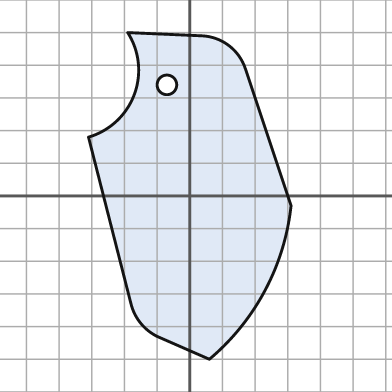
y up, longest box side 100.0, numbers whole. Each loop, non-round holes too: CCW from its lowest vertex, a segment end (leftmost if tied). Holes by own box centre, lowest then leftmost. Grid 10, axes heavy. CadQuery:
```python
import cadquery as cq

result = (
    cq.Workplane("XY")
    .moveTo(6.0, -50.0)
    .threePointArc((23.0, -29.0), (31.0, -3.0))
    .lineTo(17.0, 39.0)
    .threePointArc((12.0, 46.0), (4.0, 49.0))
    .lineTo(-19.0, 50.0)
    .threePointArc((-17.0, 31.0), (-31.0, 18.0))
    .lineTo(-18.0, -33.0)
    .threePointArc((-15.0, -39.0), (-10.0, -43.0))
    .close()
    .moveTo(-7.0, 34.0)
    .circle(3.0)
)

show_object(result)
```